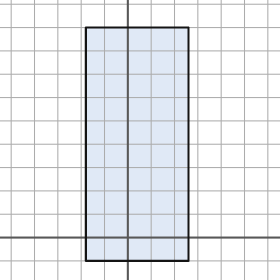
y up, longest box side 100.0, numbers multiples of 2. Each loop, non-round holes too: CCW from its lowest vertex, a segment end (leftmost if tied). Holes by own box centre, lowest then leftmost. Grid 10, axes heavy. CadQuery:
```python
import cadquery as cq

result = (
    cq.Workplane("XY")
    .moveTo(-18.0, -10.0)
    .lineTo(26.0, -10.0)
    .lineTo(26.0, 90.0)
    .lineTo(-18.0, 90.0)
    .close()
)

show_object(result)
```